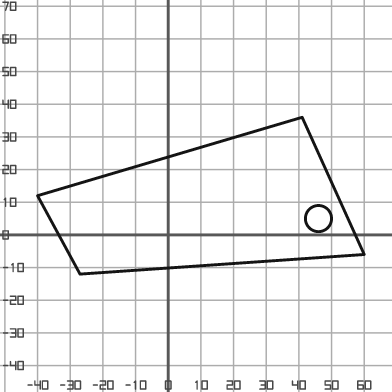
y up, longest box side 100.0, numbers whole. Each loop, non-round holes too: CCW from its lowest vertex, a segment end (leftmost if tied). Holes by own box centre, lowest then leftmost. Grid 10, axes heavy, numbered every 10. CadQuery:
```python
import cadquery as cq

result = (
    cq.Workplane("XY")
    .moveTo(-27.0, -12.0)
    .lineTo(60.0, -6.0)
    .lineTo(41.0, 36.0)
    .lineTo(-40.0, 12.0)
    .close()
    .moveTo(46.0, 5.0)
    .circle(4.0)
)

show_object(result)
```